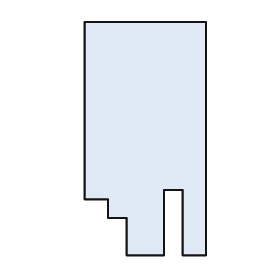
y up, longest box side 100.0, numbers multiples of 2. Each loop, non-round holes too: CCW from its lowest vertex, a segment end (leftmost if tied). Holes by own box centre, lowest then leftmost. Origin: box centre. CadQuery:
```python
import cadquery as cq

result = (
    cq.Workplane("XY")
    .moveTo(-8.0, -50.0)
    .lineTo(8.0, -50.0)
    .lineTo(8.0, -22.0)
    .lineTo(16.0, -22.0)
    .lineTo(16.0, -50.0)
    .lineTo(26.0, -50.0)
    .lineTo(26.0, 50.0)
    .lineTo(-26.0, 50.0)
    .lineTo(-26.0, -26.0)
    .lineTo(-16.0, -26.0)
    .lineTo(-16.0, -34.0)
    .lineTo(-8.0, -34.0)
    .close()
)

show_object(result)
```